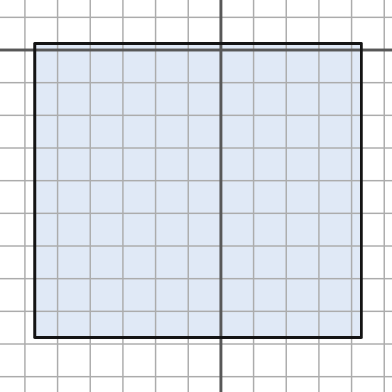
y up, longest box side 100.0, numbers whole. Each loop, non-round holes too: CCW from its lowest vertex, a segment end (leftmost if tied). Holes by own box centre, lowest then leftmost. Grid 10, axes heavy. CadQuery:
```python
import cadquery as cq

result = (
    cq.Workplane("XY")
    .moveTo(-57.0, -88.0)
    .lineTo(43.0, -88.0)
    .lineTo(43.0, 2.0)
    .lineTo(-57.0, 2.0)
    .close()
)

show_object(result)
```